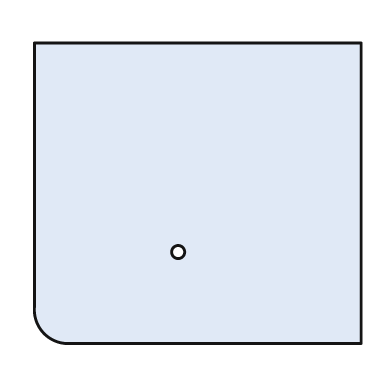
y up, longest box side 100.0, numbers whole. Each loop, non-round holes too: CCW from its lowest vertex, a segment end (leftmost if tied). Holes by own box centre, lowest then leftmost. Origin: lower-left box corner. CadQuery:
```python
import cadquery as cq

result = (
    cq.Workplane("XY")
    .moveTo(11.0, 0.0)
    .lineTo(100.0, 0.0)
    .lineTo(100.0, 92.0)
    .lineTo(0.0, 92.0)
    .lineTo(0.0, 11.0)
    .threePointArc((3.0, 3.0), (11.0, 0.0))
    .close()
    .moveTo(44.0, 28.0)
    .circle(2.0)
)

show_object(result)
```